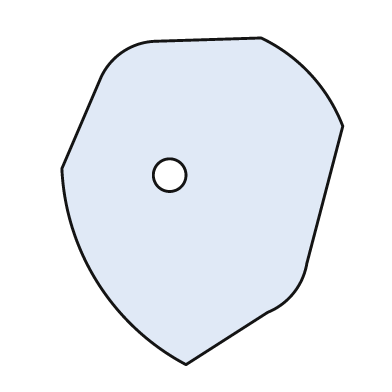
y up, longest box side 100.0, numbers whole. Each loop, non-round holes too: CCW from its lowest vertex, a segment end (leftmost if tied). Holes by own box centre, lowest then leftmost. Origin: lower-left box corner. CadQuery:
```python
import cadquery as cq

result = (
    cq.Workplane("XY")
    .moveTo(38.0, 0.0)
    .lineTo(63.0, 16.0)
    .threePointArc((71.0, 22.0), (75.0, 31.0))
    .lineTo(86.0, 73.0)
    .threePointArc((76.0, 89.0), (61.0, 100.0))
    .lineTo(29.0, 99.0)
    .threePointArc((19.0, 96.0), (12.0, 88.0))
    .lineTo(0.0, 60.0)
    .threePointArc((11.0, 25.0), (38.0, 0.0))
    .close()
    .moveTo(33.0, 58.0)
    .circle(5.0)
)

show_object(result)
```